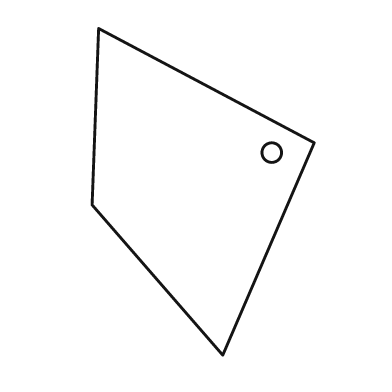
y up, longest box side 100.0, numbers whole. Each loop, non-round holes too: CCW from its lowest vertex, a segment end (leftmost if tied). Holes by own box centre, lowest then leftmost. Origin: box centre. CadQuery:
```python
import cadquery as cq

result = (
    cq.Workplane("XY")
    .moveTo(6.0, -50.0)
    .lineTo(34.0, 15.0)
    .lineTo(-32.0, 50.0)
    .lineTo(-34.0, -4.0)
    .close()
    .moveTo(21.0, 12.0)
    .circle(3.0)
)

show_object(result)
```